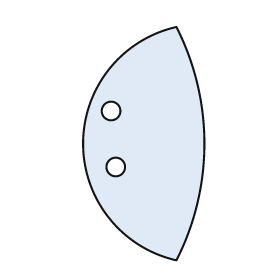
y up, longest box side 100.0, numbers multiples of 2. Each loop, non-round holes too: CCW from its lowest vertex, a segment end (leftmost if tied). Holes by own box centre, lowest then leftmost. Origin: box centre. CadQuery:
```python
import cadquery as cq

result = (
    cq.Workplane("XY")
    .moveTo(14.0, -50.0)
    .threePointArc((26.0, 0.0), (14.0, 50.0))
    .threePointArc((-26.0, 0.0), (14.0, -50.0))
    .close()
    .moveTo(-12.0, -10.0)
    .circle(4.0)
    .moveTo(-14.0, 14.0)
    .circle(4.0)
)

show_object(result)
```